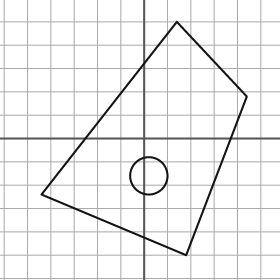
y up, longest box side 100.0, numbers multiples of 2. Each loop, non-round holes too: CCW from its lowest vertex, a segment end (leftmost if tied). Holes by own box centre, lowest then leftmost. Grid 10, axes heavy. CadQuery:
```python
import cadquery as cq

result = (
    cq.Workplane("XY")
    .moveTo(18.0, -50.0)
    .lineTo(44.0, 18.0)
    .lineTo(14.0, 50.0)
    .lineTo(-44.0, -24.0)
    .close()
    .moveTo(2.0, -16.0)
    .circle(8.0)
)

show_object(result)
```